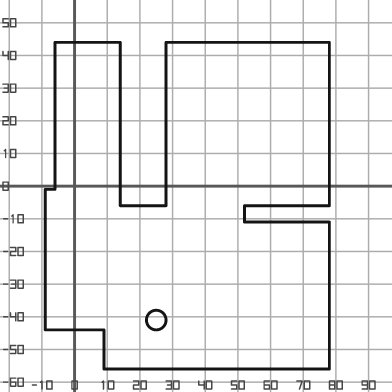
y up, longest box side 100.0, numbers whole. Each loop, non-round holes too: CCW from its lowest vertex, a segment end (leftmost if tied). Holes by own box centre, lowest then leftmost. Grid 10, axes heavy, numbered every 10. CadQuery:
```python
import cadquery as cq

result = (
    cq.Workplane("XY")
    .moveTo(9.0, -56.0)
    .lineTo(78.0, -56.0)
    .lineTo(78.0, -11.0)
    .lineTo(52.0, -11.0)
    .lineTo(52.0, -6.0)
    .lineTo(78.0, -6.0)
    .lineTo(78.0, 44.0)
    .lineTo(28.0, 44.0)
    .lineTo(28.0, -6.0)
    .lineTo(14.0, -6.0)
    .lineTo(14.0, 44.0)
    .lineTo(-6.0, 44.0)
    .lineTo(-6.0, -1.0)
    .lineTo(-9.0, -1.0)
    .lineTo(-9.0, -44.0)
    .lineTo(9.0, -44.0)
    .close()
    .moveTo(25.0, -41.0)
    .circle(3.0)
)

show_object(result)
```